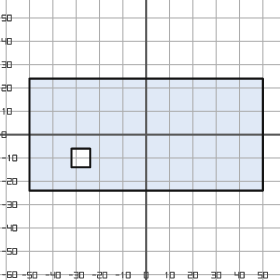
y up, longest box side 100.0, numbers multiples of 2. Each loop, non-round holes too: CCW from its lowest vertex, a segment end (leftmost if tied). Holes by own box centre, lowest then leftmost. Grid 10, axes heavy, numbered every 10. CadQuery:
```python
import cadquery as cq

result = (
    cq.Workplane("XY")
    .moveTo(-50.0, -24.0)
    .lineTo(50.0, -24.0)
    .lineTo(50.0, 24.0)
    .lineTo(-50.0, 24.0)
    .close()
    .moveTo(-32.0, -14.0)
    .lineTo(-24.0, -14.0)
    .lineTo(-24.0, -6.0)
    .lineTo(-32.0, -6.0)
    .close()
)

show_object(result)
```